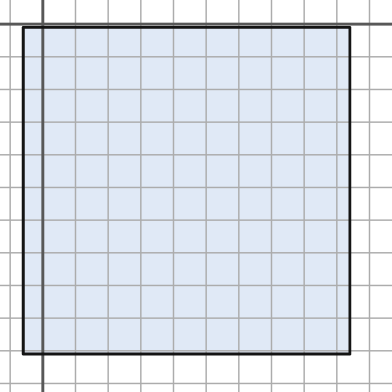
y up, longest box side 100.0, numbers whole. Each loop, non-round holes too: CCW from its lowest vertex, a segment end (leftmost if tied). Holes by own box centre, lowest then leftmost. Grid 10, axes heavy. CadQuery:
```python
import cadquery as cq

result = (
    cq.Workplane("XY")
    .moveTo(-6.0, -101.0)
    .lineTo(94.0, -101.0)
    .lineTo(94.0, -1.0)
    .lineTo(-6.0, -1.0)
    .close()
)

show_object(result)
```